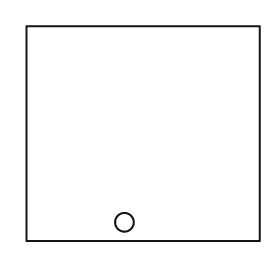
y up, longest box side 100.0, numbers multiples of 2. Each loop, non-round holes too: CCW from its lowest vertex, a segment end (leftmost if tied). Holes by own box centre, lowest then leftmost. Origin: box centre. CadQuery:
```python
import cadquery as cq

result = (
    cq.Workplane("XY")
    .moveTo(-50.0, -46.0)
    .lineTo(50.0, -46.0)
    .lineTo(50.0, 46.0)
    .lineTo(-50.0, 46.0)
    .close()
    .moveTo(-8.0, -38.0)
    .circle(4.0)
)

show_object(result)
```